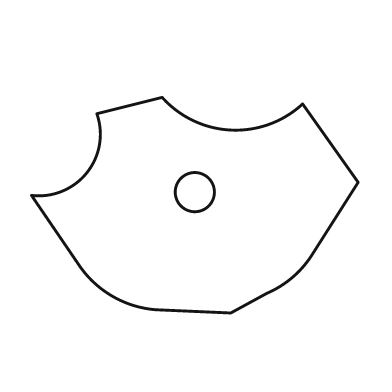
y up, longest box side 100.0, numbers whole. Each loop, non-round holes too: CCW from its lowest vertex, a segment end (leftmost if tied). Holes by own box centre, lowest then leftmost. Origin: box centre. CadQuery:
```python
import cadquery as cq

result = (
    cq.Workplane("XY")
    .moveTo(11.0, -33.0)
    .lineTo(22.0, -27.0)
    .threePointArc((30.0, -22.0), (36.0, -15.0))
    .lineTo(50.0, 7.0)
    .lineTo(33.0, 31.0)
    .threePointArc((11.0, 23.0), (-10.0, 33.0))
    .lineTo(-30.0, 28.0)
    .threePointArc((-33.0, 10.0), (-50.0, 3.0))
    .lineTo(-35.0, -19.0)
    .threePointArc((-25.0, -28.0), (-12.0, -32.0))
    .close()
    .moveTo(0.0, 4.0)
    .circle(6.0)
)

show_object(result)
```